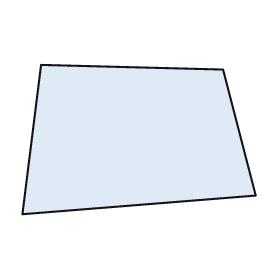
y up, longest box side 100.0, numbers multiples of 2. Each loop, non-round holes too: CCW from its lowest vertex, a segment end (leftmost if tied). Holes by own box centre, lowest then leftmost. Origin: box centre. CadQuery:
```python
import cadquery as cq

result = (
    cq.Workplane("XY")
    .moveTo(-50.0, -32.0)
    .lineTo(50.0, -24.0)
    .lineTo(36.0, 30.0)
    .lineTo(-42.0, 32.0)
    .close()
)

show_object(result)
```